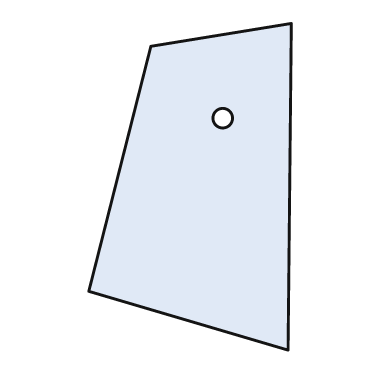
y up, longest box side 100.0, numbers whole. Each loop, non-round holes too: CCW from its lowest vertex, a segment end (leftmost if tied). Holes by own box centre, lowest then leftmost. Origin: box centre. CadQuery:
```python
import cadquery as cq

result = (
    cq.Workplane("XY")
    .moveTo(30.0, -50.0)
    .lineTo(31.0, 50.0)
    .lineTo(-12.0, 43.0)
    .lineTo(-31.0, -32.0)
    .close()
    .moveTo(10.0, 21.0)
    .circle(3.0)
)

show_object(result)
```